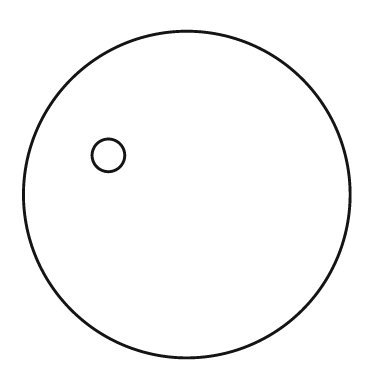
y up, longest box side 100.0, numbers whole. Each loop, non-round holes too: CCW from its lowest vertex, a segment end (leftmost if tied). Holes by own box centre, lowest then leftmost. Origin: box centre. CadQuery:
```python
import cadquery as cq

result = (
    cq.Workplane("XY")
    .moveTo(0.0, 0.0)
    .circle(50.0)
    .moveTo(-24.0, 12.0)
    .circle(5.0)
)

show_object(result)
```